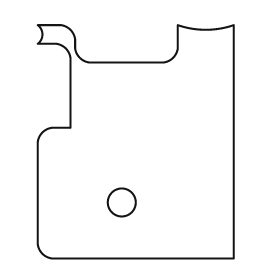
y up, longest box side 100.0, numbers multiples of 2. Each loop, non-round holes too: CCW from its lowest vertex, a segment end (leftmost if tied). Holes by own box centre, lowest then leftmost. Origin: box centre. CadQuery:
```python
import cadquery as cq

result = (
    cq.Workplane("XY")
    .moveTo(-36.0, -50.0)
    .lineTo(42.0, -50.0)
    .lineTo(42.0, 50.0)
    .threePointArc((30.0, 48.0), (18.0, 50.0))
    .lineTo(18.0, 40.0)
    .threePointArc((16.0, 36.0), (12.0, 34.0))
    .lineTo(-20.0, 34.0)
    .threePointArc((-24.0, 36.0), (-26.0, 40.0))
    .lineTo(-26.0, 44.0)
    .threePointArc((-28.0, 48.0), (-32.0, 50.0))
    .lineTo(-42.0, 50.0)
    .threePointArc((-40.0, 46.0), (-42.0, 42.0))
    .lineTo(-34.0, 42.0)
    .threePointArc((-30.0, 40.0), (-28.0, 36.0))
    .lineTo(-28.0, 6.0)
    .lineTo(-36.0, 6.0)
    .threePointArc((-40.0, 4.0), (-42.0, 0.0))
    .lineTo(-42.0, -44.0)
    .threePointArc((-40.0, -48.0), (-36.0, -50.0))
    .close()
    .moveTo(-6.0, -26.0)
    .circle(6.0)
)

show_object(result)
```